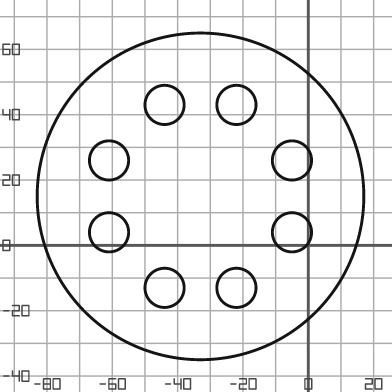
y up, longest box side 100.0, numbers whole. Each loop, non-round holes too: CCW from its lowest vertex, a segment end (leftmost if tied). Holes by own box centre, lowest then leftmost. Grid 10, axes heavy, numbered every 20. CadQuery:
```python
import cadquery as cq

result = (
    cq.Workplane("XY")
    .moveTo(-33.0, 15.0)
    .circle(50.0)
    .moveTo(-44.0, -13.0)
    .circle(6.0)
    .moveTo(-22.0, -13.0)
    .circle(6.0)
    .moveTo(-61.0, 4.0)
    .circle(6.0)
    .moveTo(-5.0, 4.0)
    .circle(6.0)
    .moveTo(-61.0, 26.0)
    .circle(6.0)
    .moveTo(-5.0, 26.0)
    .circle(6.0)
    .moveTo(-44.0, 43.0)
    .circle(6.0)
    .moveTo(-22.0, 43.0)
    .circle(6.0)
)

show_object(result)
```